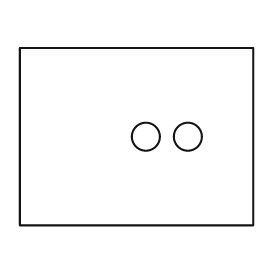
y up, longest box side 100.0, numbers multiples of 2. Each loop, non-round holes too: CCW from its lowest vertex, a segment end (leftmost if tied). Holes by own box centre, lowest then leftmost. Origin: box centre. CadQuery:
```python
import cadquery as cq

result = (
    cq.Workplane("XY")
    .moveTo(-50.0, -38.0)
    .lineTo(50.0, -38.0)
    .lineTo(50.0, 38.0)
    .lineTo(-50.0, 38.0)
    .close()
    .moveTo(4.0, 0.0)
    .circle(6.0)
    .moveTo(22.0, 0.0)
    .circle(6.0)
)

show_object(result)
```